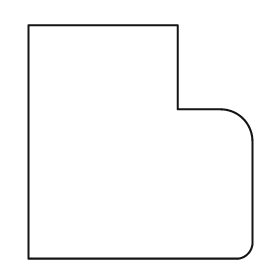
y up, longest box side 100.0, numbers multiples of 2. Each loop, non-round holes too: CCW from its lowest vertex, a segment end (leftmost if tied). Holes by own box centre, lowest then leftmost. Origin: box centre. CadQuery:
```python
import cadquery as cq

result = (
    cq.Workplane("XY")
    .moveTo(-48.0, -50.0)
    .lineTo(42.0, -50.0)
    .threePointArc((46.0, -48.0), (48.0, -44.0))
    .lineTo(48.0, 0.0)
    .threePointArc((44.0, 10.0), (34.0, 14.0))
    .lineTo(16.0, 14.0)
    .lineTo(16.0, 50.0)
    .lineTo(-48.0, 50.0)
    .close()
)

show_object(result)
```